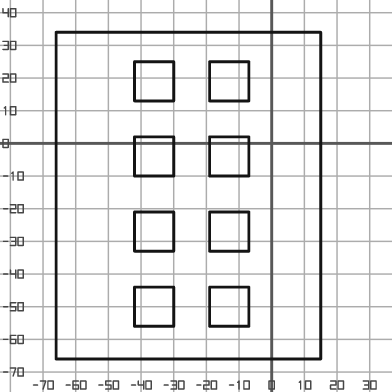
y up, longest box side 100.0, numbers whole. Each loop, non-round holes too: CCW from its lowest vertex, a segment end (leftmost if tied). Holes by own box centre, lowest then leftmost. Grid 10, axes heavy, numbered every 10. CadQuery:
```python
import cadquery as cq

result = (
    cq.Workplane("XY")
    .moveTo(-66.0, -66.0)
    .lineTo(15.0, -66.0)
    .lineTo(15.0, 34.0)
    .lineTo(-66.0, 34.0)
    .close()
    .moveTo(-42.0, -56.0)
    .lineTo(-30.0, -56.0)
    .lineTo(-30.0, -44.0)
    .lineTo(-42.0, -44.0)
    .close()
    .moveTo(-19.0, -56.0)
    .lineTo(-7.0, -56.0)
    .lineTo(-7.0, -44.0)
    .lineTo(-19.0, -44.0)
    .close()
    .moveTo(-42.0, -33.0)
    .lineTo(-30.0, -33.0)
    .lineTo(-30.0, -21.0)
    .lineTo(-42.0, -21.0)
    .close()
    .moveTo(-19.0, -33.0)
    .lineTo(-7.0, -33.0)
    .lineTo(-7.0, -21.0)
    .lineTo(-19.0, -21.0)
    .close()
    .moveTo(-42.0, -10.0)
    .lineTo(-30.0, -10.0)
    .lineTo(-30.0, 2.0)
    .lineTo(-42.0, 2.0)
    .close()
    .moveTo(-19.0, -10.0)
    .lineTo(-7.0, -10.0)
    .lineTo(-7.0, 2.0)
    .lineTo(-19.0, 2.0)
    .close()
    .moveTo(-42.0, 13.0)
    .lineTo(-30.0, 13.0)
    .lineTo(-30.0, 25.0)
    .lineTo(-42.0, 25.0)
    .close()
    .moveTo(-19.0, 13.0)
    .lineTo(-7.0, 13.0)
    .lineTo(-7.0, 25.0)
    .lineTo(-19.0, 25.0)
    .close()
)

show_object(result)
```